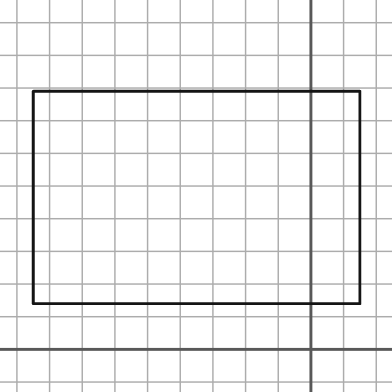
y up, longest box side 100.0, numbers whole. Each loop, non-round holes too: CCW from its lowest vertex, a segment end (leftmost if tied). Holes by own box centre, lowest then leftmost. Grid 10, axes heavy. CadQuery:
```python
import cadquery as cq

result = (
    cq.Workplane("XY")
    .moveTo(-85.0, 14.0)
    .lineTo(15.0, 14.0)
    .lineTo(15.0, 79.0)
    .lineTo(-85.0, 79.0)
    .close()
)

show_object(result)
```